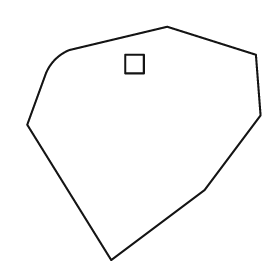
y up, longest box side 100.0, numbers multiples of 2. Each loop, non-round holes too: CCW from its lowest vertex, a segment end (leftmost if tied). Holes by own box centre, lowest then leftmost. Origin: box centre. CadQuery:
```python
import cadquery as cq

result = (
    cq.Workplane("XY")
    .moveTo(-14.0, -50.0)
    .lineTo(26.0, -20.0)
    .lineTo(50.0, 12.0)
    .lineTo(48.0, 38.0)
    .lineTo(10.0, 50.0)
    .lineTo(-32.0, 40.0)
    .threePointArc((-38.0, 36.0), (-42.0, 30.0))
    .lineTo(-50.0, 8.0)
    .close()
    .moveTo(-8.0, 30.0)
    .lineTo(0.0, 30.0)
    .lineTo(0.0, 38.0)
    .lineTo(-8.0, 38.0)
    .close()
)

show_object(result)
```